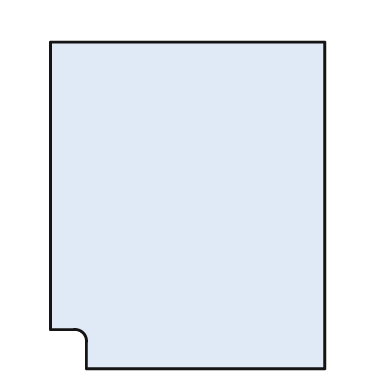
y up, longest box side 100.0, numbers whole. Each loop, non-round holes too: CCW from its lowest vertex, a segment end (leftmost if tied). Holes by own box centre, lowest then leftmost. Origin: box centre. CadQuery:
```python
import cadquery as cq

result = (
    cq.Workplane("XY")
    .moveTo(-31.0, -50.0)
    .lineTo(42.0, -50.0)
    .lineTo(42.0, 50.0)
    .lineTo(-42.0, 50.0)
    .lineTo(-42.0, -38.0)
    .lineTo(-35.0, -38.0)
    .threePointArc((-32.0, -39.0), (-31.0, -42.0))
    .close()
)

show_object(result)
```